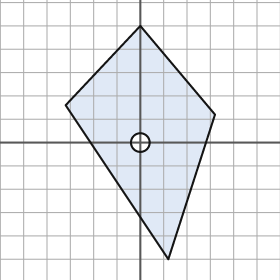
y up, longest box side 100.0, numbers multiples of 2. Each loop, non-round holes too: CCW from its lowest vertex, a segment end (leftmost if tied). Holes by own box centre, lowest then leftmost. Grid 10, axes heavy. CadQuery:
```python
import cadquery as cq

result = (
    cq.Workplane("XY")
    .moveTo(12.0, -50.0)
    .lineTo(32.0, 12.0)
    .lineTo(0.0, 50.0)
    .lineTo(-32.0, 16.0)
    .close()
    .moveTo(0.0, 0.0)
    .circle(4.0)
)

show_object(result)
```